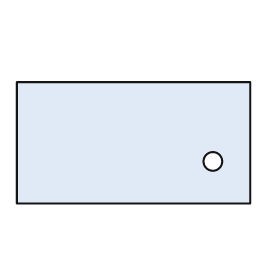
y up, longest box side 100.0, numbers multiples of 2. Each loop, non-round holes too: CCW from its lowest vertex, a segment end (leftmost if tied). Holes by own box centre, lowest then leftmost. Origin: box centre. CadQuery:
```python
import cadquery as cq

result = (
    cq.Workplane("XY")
    .moveTo(-50.0, -26.0)
    .lineTo(50.0, -26.0)
    .lineTo(50.0, 26.0)
    .lineTo(-50.0, 26.0)
    .close()
    .moveTo(34.0, -8.0)
    .circle(4.0)
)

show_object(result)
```